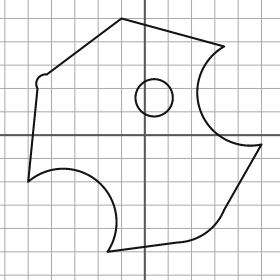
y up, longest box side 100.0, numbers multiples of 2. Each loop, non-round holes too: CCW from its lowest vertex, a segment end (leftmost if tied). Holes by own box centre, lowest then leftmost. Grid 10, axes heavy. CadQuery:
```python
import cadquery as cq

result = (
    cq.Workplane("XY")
    .moveTo(-16.0, -50.0)
    .lineTo(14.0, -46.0)
    .threePointArc((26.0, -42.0), (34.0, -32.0))
    .lineTo(50.0, -4.0)
    .threePointArc((24.0, 10.0), (34.0, 38.0))
    .lineTo(-10.0, 50.0)
    .lineTo(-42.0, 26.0)
    .threePointArc((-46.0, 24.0), (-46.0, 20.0))
    .lineTo(-50.0, -20.0)
    .threePointArc((-20.0, -20.0), (-16.0, -50.0))
    .close()
    .moveTo(4.0, 16.0)
    .circle(8.0)
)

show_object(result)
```